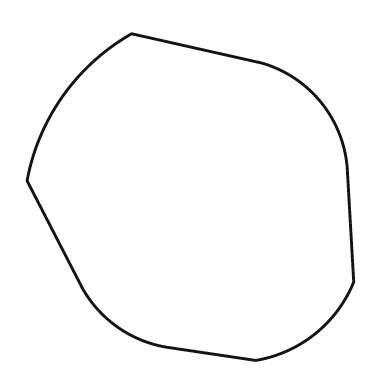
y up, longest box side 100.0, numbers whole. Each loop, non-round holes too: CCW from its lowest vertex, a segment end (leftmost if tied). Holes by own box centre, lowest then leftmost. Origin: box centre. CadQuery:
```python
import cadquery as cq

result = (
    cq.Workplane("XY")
    .moveTo(20.0, -50.0)
    .threePointArc((38.0, -42.0), (50.0, -26.0))
    .lineTo(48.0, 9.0)
    .threePointArc((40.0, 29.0), (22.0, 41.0))
    .lineTo(-18.0, 50.0)
    .threePointArc((-39.0, 31.0), (-50.0, 5.0))
    .lineTo(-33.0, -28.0)
    .threePointArc((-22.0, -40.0), (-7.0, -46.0))
    .close()
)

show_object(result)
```